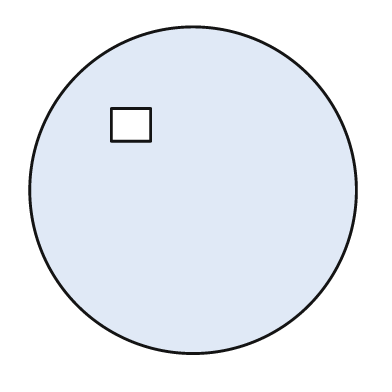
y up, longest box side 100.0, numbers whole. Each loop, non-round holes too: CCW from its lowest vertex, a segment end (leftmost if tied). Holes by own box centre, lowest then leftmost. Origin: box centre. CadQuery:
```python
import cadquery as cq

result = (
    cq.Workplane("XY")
    .moveTo(0.0, 0.0)
    .circle(50.0)
    .moveTo(-25.0, 15.0)
    .lineTo(-13.0, 15.0)
    .lineTo(-13.0, 25.0)
    .lineTo(-25.0, 25.0)
    .close()
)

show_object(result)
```